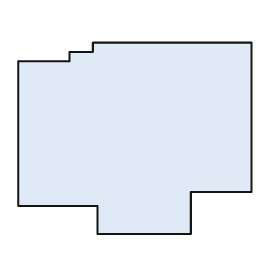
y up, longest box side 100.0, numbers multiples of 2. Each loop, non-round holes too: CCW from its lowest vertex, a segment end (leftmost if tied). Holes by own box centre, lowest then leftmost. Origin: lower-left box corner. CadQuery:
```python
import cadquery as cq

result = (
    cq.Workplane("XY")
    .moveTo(34.0, 0.0)
    .lineTo(74.0, 0.0)
    .lineTo(74.0, 18.0)
    .lineTo(100.0, 18.0)
    .lineTo(100.0, 82.0)
    .lineTo(32.0, 82.0)
    .lineTo(32.0, 78.0)
    .lineTo(22.0, 78.0)
    .lineTo(22.0, 74.0)
    .lineTo(0.0, 74.0)
    .lineTo(0.0, 12.0)
    .lineTo(34.0, 12.0)
    .close()
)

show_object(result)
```